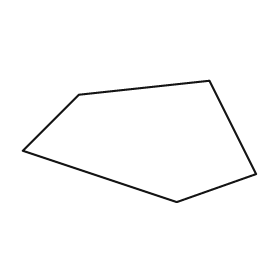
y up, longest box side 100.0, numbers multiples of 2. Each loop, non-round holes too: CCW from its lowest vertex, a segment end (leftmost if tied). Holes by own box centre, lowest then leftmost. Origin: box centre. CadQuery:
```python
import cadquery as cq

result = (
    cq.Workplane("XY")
    .moveTo(16.0, -26.0)
    .lineTo(50.0, -14.0)
    .lineTo(30.0, 26.0)
    .lineTo(-26.0, 20.0)
    .lineTo(-50.0, -4.0)
    .close()
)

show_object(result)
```